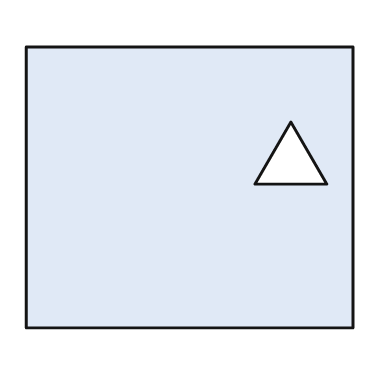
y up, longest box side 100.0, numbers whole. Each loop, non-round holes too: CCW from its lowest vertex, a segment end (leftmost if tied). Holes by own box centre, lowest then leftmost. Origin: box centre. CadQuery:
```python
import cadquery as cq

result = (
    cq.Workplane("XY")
    .moveTo(-50.0, -43.0)
    .lineTo(50.0, -43.0)
    .lineTo(50.0, 43.0)
    .lineTo(-50.0, 43.0)
    .close()
    .moveTo(20.0, 1.0)
    .lineTo(42.0, 1.0)
    .lineTo(31.0, 20.0)
    .close()
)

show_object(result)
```